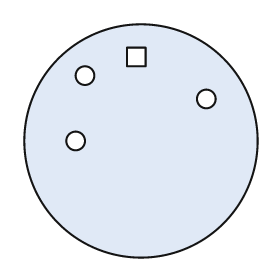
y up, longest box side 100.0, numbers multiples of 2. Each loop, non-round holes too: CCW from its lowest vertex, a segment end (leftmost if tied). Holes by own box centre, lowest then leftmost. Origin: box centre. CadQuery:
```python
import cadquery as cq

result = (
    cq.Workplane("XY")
    .moveTo(0.0, 0.0)
    .circle(50.0)
    .moveTo(-28.0, 0.0)
    .circle(4.0)
    .moveTo(28.0, 18.0)
    .circle(4.0)
    .moveTo(-24.0, 28.0)
    .circle(4.0)
    .moveTo(-6.0, 32.0)
    .lineTo(2.0, 32.0)
    .lineTo(2.0, 40.0)
    .lineTo(-6.0, 40.0)
    .close()
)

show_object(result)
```